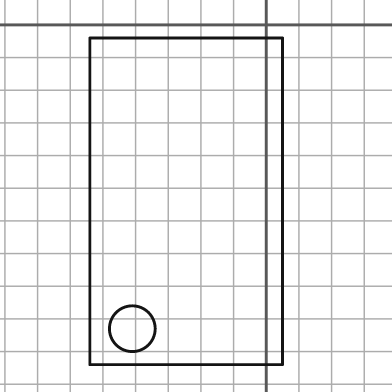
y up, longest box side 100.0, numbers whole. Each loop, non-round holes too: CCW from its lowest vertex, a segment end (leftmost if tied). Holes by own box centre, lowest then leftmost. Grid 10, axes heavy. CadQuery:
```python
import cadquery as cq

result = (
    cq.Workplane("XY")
    .moveTo(-54.0, -104.0)
    .lineTo(5.0, -104.0)
    .lineTo(5.0, -4.0)
    .lineTo(-54.0, -4.0)
    .close()
    .moveTo(-41.0, -93.0)
    .circle(7.0)
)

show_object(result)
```